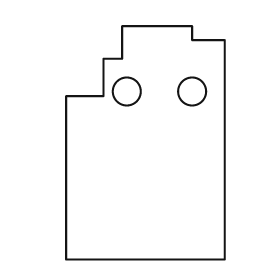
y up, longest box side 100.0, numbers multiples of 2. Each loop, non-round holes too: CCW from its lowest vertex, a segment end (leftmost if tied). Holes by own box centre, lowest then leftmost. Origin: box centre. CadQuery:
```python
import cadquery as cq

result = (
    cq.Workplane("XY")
    .moveTo(-34.0, -50.0)
    .lineTo(34.0, -50.0)
    .lineTo(34.0, 44.0)
    .lineTo(20.0, 44.0)
    .lineTo(20.0, 50.0)
    .lineTo(-10.0, 50.0)
    .lineTo(-10.0, 36.0)
    .lineTo(-18.0, 36.0)
    .lineTo(-18.0, 20.0)
    .lineTo(-34.0, 20.0)
    .close()
    .moveTo(-8.0, 22.0)
    .circle(6.0)
    .moveTo(20.0, 22.0)
    .circle(6.0)
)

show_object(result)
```